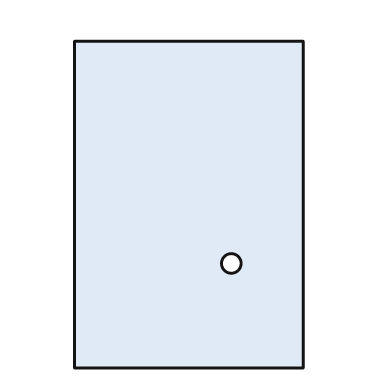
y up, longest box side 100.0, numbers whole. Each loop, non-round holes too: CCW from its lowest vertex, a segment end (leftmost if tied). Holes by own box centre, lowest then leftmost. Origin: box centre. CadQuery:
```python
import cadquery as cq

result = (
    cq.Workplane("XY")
    .moveTo(-35.0, -50.0)
    .lineTo(35.0, -50.0)
    .lineTo(35.0, 50.0)
    .lineTo(-35.0, 50.0)
    .close()
    .moveTo(13.0, -18.0)
    .circle(3.0)
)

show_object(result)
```